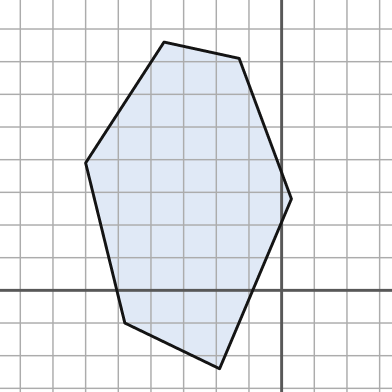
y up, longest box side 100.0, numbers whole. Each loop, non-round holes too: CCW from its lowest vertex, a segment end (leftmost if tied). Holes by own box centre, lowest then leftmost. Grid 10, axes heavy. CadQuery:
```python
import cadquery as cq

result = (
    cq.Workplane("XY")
    .moveTo(-19.0, -24.0)
    .lineTo(3.0, 28.0)
    .lineTo(-13.0, 71.0)
    .lineTo(-36.0, 76.0)
    .lineTo(-60.0, 39.0)
    .lineTo(-48.0, -10.0)
    .close()
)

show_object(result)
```